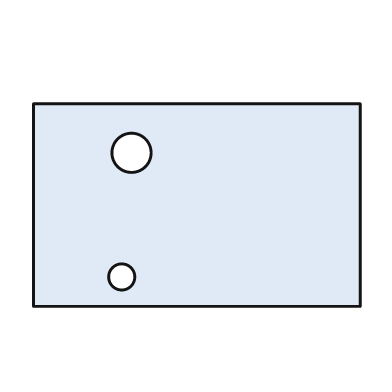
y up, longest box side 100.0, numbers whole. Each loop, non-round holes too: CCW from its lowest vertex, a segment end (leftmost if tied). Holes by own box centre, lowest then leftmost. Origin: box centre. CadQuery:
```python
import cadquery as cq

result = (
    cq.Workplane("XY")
    .moveTo(-50.0, -31.0)
    .lineTo(50.0, -31.0)
    .lineTo(50.0, 31.0)
    .lineTo(-50.0, 31.0)
    .close()
    .moveTo(-23.0, -22.0)
    .circle(4.0)
    .moveTo(-20.0, 16.0)
    .circle(6.0)
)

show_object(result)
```